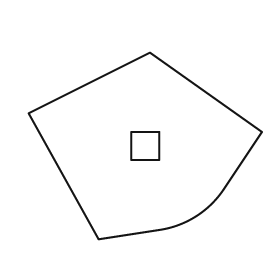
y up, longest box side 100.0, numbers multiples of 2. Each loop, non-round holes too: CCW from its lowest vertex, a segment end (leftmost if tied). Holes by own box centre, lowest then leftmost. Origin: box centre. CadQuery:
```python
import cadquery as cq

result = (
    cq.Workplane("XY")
    .moveTo(-20.0, -40.0)
    .lineTo(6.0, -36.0)
    .threePointArc((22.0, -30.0), (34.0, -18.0))
    .lineTo(50.0, 6.0)
    .lineTo(2.0, 40.0)
    .lineTo(-50.0, 14.0)
    .close()
    .moveTo(-6.0, -6.0)
    .lineTo(6.0, -6.0)
    .lineTo(6.0, 6.0)
    .lineTo(-6.0, 6.0)
    .close()
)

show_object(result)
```